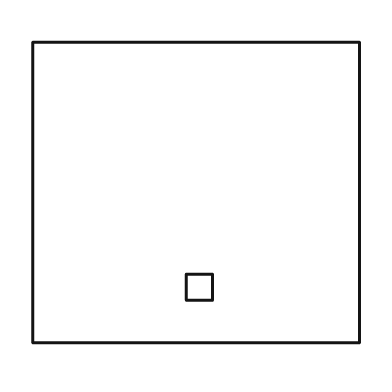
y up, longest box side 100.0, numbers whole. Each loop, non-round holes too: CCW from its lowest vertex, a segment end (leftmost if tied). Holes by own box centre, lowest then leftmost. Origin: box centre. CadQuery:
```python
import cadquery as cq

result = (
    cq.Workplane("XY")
    .moveTo(-50.0, -46.0)
    .lineTo(50.0, -46.0)
    .lineTo(50.0, 46.0)
    .lineTo(-50.0, 46.0)
    .close()
    .moveTo(-3.0, -33.0)
    .lineTo(5.0, -33.0)
    .lineTo(5.0, -25.0)
    .lineTo(-3.0, -25.0)
    .close()
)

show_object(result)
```